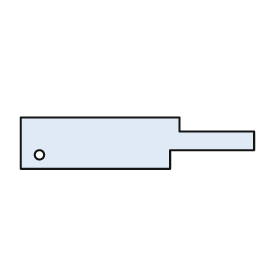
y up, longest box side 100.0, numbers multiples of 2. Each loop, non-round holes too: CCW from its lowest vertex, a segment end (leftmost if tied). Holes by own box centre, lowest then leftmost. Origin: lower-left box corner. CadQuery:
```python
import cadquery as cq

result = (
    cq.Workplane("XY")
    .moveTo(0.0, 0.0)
    .lineTo(64.0, 0.0)
    .lineTo(64.0, 8.0)
    .lineTo(100.0, 8.0)
    .lineTo(100.0, 16.0)
    .lineTo(68.0, 16.0)
    .lineTo(68.0, 22.0)
    .lineTo(0.0, 22.0)
    .close()
    .moveTo(8.0, 6.0)
    .circle(2.0)
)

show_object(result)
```